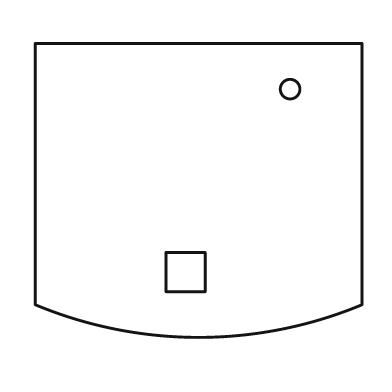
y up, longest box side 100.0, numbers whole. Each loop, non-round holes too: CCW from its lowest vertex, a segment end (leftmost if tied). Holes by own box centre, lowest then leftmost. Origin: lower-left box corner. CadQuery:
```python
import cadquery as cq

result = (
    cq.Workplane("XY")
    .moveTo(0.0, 10.0)
    .threePointArc((50.0, 0.0), (100.0, 10.0))
    .lineTo(100.0, 90.0)
    .lineTo(0.0, 90.0)
    .close()
    .moveTo(40.0, 14.0)
    .lineTo(52.0, 14.0)
    .lineTo(52.0, 26.0)
    .lineTo(40.0, 26.0)
    .close()
    .moveTo(78.0, 76.0)
    .circle(3.0)
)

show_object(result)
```